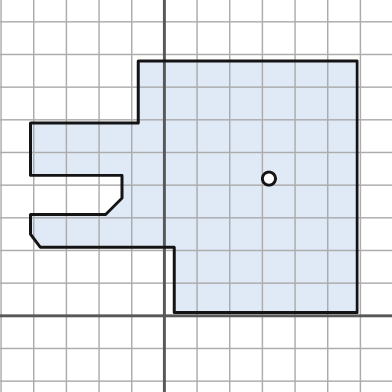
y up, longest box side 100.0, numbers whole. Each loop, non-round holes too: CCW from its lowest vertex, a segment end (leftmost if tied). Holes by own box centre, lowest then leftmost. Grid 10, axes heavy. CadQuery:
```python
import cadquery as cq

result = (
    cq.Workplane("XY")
    .moveTo(3.0, 1.0)
    .lineTo(59.0, 1.0)
    .lineTo(59.0, 78.0)
    .lineTo(-8.0, 78.0)
    .lineTo(-8.0, 59.0)
    .lineTo(-41.0, 59.0)
    .lineTo(-41.0, 43.0)
    .lineTo(-13.0, 43.0)
    .lineTo(-13.0, 36.0)
    .lineTo(-18.0, 31.0)
    .lineTo(-41.0, 31.0)
    .lineTo(-41.0, 25.0)
    .lineTo(-38.0, 21.0)
    .lineTo(3.0, 21.0)
    .close()
    .moveTo(32.0, 42.0)
    .circle(2.0)
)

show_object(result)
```